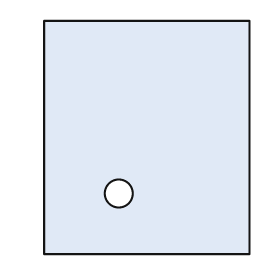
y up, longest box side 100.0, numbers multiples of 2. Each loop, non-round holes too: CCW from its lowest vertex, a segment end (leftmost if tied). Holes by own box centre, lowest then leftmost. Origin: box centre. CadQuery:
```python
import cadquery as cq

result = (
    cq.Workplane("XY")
    .moveTo(-44.0, -50.0)
    .lineTo(44.0, -50.0)
    .lineTo(44.0, 50.0)
    .lineTo(-44.0, 50.0)
    .close()
    .moveTo(-12.0, -24.0)
    .circle(6.0)
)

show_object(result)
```